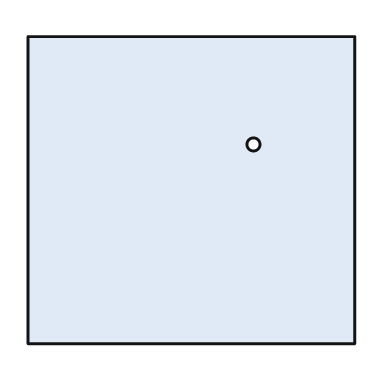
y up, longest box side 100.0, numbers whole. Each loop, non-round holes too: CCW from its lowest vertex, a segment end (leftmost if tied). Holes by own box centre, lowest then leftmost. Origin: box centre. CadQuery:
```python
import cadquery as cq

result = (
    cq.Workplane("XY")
    .moveTo(-50.0, -47.0)
    .lineTo(50.0, -47.0)
    .lineTo(50.0, 47.0)
    .lineTo(-50.0, 47.0)
    .close()
    .moveTo(19.0, 14.0)
    .circle(2.0)
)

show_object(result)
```